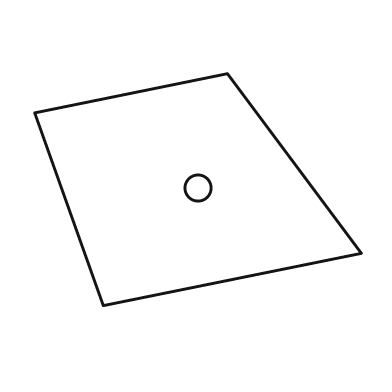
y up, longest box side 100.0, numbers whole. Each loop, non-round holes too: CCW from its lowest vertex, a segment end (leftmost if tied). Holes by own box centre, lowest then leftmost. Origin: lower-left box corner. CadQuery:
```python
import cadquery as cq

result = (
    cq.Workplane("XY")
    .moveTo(21.0, 0.0)
    .lineTo(100.0, 16.0)
    .lineTo(59.0, 71.0)
    .lineTo(0.0, 59.0)
    .close()
    .moveTo(50.0, 36.0)
    .circle(4.0)
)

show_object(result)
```